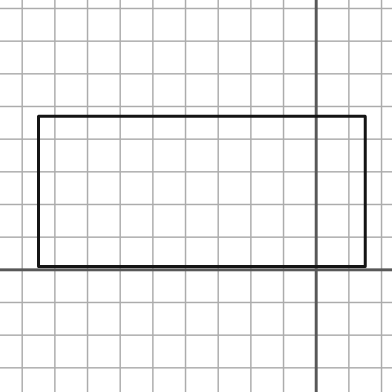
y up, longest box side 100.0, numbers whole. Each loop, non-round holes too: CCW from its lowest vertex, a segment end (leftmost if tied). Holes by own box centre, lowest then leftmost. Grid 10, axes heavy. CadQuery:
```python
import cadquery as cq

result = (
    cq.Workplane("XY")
    .moveTo(-85.0, 1.0)
    .lineTo(15.0, 1.0)
    .lineTo(15.0, 47.0)
    .lineTo(-85.0, 47.0)
    .close()
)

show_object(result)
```